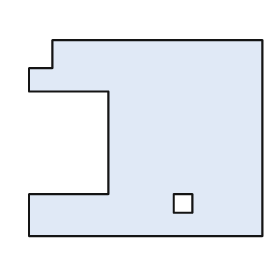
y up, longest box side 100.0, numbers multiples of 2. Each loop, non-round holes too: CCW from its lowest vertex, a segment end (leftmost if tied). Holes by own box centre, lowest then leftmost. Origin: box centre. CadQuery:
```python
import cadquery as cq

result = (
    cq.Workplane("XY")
    .moveTo(-50.0, -42.0)
    .lineTo(50.0, -42.0)
    .lineTo(50.0, 42.0)
    .lineTo(-40.0, 42.0)
    .lineTo(-40.0, 30.0)
    .lineTo(-50.0, 30.0)
    .lineTo(-50.0, 20.0)
    .lineTo(-16.0, 20.0)
    .lineTo(-16.0, -24.0)
    .lineTo(-50.0, -24.0)
    .close()
    .moveTo(12.0, -32.0)
    .lineTo(20.0, -32.0)
    .lineTo(20.0, -24.0)
    .lineTo(12.0, -24.0)
    .close()
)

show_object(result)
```